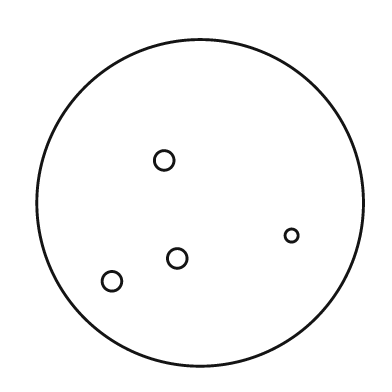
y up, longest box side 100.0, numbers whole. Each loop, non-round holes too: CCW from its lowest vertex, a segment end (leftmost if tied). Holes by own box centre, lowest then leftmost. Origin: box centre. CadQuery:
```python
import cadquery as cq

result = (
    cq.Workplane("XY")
    .moveTo(0.0, 0.0)
    .circle(50.0)
    .moveTo(-27.0, -24.0)
    .circle(3.0)
    .moveTo(-7.0, -17.0)
    .circle(3.0)
    .moveTo(28.0, -10.0)
    .circle(2.0)
    .moveTo(-11.0, 13.0)
    .circle(3.0)
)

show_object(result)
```